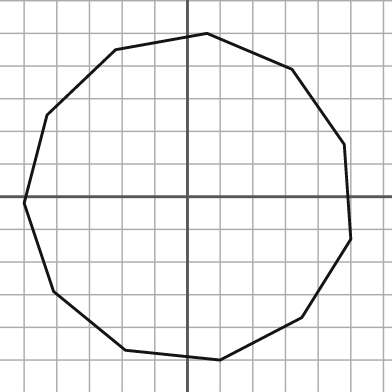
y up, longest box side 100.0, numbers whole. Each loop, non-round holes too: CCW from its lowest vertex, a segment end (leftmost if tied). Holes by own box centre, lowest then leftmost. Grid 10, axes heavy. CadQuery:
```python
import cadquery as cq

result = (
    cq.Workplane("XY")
    .moveTo(10.0, -50.0)
    .lineTo(35.0, -37.0)
    .lineTo(50.0, -13.0)
    .lineTo(48.0, 16.0)
    .lineTo(32.0, 39.0)
    .lineTo(6.0, 50.0)
    .lineTo(-22.0, 45.0)
    .lineTo(-43.0, 25.0)
    .lineTo(-50.0, -2.0)
    .lineTo(-41.0, -29.0)
    .lineTo(-19.0, -47.0)
    .close()
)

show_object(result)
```